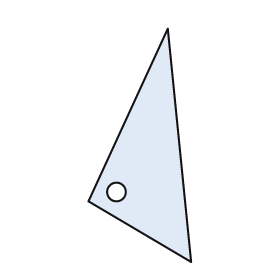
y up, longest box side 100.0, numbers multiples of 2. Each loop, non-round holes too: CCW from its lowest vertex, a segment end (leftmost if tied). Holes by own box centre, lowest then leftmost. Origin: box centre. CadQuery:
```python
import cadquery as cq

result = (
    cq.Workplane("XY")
    .moveTo(22.0, -50.0)
    .lineTo(12.0, 50.0)
    .lineTo(-22.0, -24.0)
    .close()
    .moveTo(-10.0, -20.0)
    .circle(4.0)
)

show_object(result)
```